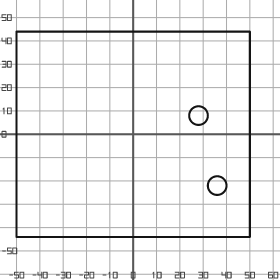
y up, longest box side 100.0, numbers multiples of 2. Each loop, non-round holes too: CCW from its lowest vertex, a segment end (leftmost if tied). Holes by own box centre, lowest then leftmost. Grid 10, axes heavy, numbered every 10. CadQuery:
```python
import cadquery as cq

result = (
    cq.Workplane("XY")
    .moveTo(-50.0, -44.0)
    .lineTo(50.0, -44.0)
    .lineTo(50.0, 44.0)
    .lineTo(-50.0, 44.0)
    .close()
    .moveTo(36.0, -22.0)
    .circle(4.0)
    .moveTo(28.0, 8.0)
    .circle(4.0)
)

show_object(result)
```